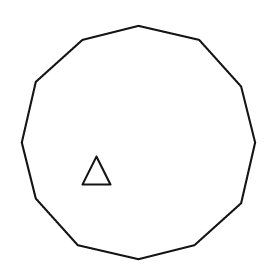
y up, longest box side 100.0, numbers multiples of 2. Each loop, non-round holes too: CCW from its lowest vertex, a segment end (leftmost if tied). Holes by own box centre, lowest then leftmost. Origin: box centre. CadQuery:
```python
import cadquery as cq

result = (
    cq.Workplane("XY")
    .moveTo(0.0, -50.0)
    .lineTo(24.0, -44.0)
    .lineTo(44.0, -26.0)
    .lineTo(50.0, 0.0)
    .lineTo(44.0, 24.0)
    .lineTo(26.0, 44.0)
    .lineTo(0.0, 50.0)
    .lineTo(-24.0, 44.0)
    .lineTo(-44.0, 26.0)
    .lineTo(-50.0, 0.0)
    .lineTo(-44.0, -24.0)
    .lineTo(-26.0, -44.0)
    .close()
    .moveTo(-24.0, -18.0)
    .lineTo(-12.0, -18.0)
    .lineTo(-18.0, -6.0)
    .close()
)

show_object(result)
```